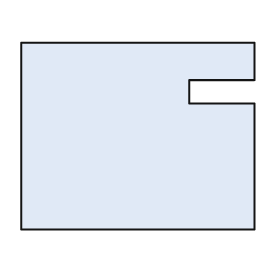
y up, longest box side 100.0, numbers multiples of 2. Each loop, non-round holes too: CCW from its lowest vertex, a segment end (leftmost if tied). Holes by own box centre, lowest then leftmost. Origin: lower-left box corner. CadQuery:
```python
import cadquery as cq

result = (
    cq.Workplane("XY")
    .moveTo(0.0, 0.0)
    .lineTo(100.0, 0.0)
    .lineTo(100.0, 54.0)
    .lineTo(72.0, 54.0)
    .lineTo(72.0, 64.0)
    .lineTo(100.0, 64.0)
    .lineTo(100.0, 80.0)
    .lineTo(0.0, 80.0)
    .close()
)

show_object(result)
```